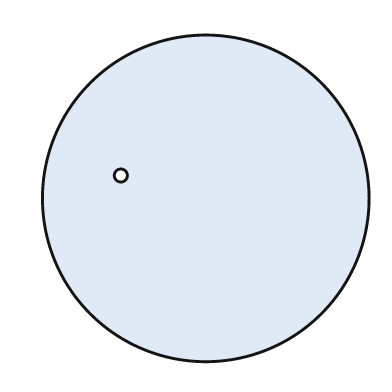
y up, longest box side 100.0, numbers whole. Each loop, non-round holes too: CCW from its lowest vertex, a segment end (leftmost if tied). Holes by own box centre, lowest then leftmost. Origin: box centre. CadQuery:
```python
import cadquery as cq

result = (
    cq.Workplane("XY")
    .moveTo(0.0, 0.0)
    .circle(50.0)
    .moveTo(-26.0, 7.0)
    .circle(2.0)
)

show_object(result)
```